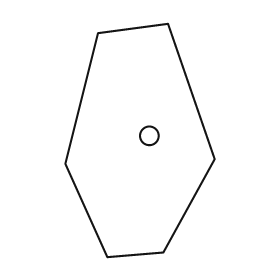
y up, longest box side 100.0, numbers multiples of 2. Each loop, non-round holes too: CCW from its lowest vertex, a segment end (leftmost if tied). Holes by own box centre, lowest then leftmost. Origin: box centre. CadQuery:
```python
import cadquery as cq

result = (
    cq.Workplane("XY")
    .moveTo(-14.0, -50.0)
    .lineTo(10.0, -48.0)
    .lineTo(32.0, -8.0)
    .lineTo(12.0, 50.0)
    .lineTo(-18.0, 46.0)
    .lineTo(-32.0, -10.0)
    .close()
    .moveTo(4.0, 2.0)
    .circle(4.0)
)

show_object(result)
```